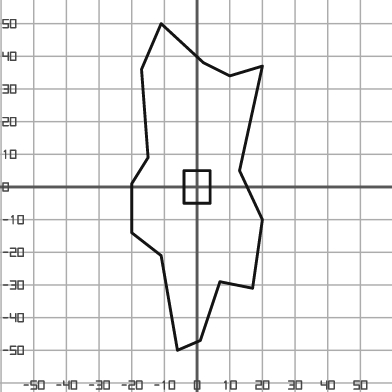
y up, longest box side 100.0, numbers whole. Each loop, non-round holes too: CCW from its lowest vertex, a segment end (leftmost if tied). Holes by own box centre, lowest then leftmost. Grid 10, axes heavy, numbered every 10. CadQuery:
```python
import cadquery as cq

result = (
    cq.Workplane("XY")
    .moveTo(-6.0, -50.0)
    .lineTo(1.0, -47.0)
    .lineTo(7.0, -29.0)
    .lineTo(17.0, -31.0)
    .lineTo(20.0, -10.0)
    .lineTo(13.0, 5.0)
    .lineTo(20.0, 37.0)
    .lineTo(10.0, 34.0)
    .lineTo(2.0, 38.0)
    .lineTo(-11.0, 50.0)
    .lineTo(-17.0, 36.0)
    .lineTo(-15.0, 9.0)
    .lineTo(-20.0, 1.0)
    .lineTo(-20.0, -14.0)
    .lineTo(-11.0, -21.0)
    .close()
    .moveTo(-4.0, -5.0)
    .lineTo(4.0, -5.0)
    .lineTo(4.0, 5.0)
    .lineTo(-4.0, 5.0)
    .close()
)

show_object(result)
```